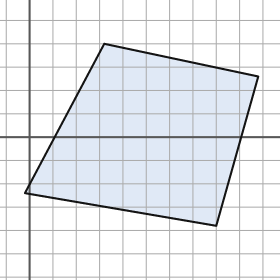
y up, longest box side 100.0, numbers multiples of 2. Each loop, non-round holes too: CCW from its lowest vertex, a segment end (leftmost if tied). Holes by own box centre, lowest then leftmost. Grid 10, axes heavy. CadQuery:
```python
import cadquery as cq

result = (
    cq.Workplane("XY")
    .moveTo(80.0, -38.0)
    .lineTo(98.0, 26.0)
    .lineTo(32.0, 40.0)
    .lineTo(-2.0, -24.0)
    .close()
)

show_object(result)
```